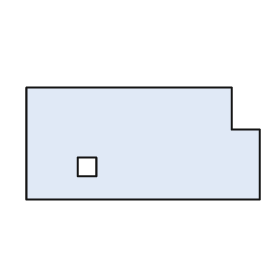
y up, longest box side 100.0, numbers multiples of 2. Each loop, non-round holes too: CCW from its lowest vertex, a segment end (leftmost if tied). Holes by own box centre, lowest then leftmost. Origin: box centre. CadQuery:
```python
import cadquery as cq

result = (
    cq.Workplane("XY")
    .moveTo(-50.0, -24.0)
    .lineTo(50.0, -24.0)
    .lineTo(50.0, 6.0)
    .lineTo(38.0, 6.0)
    .lineTo(38.0, 24.0)
    .lineTo(-50.0, 24.0)
    .close()
    .moveTo(-28.0, -14.0)
    .lineTo(-20.0, -14.0)
    .lineTo(-20.0, -6.0)
    .lineTo(-28.0, -6.0)
    .close()
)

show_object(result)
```